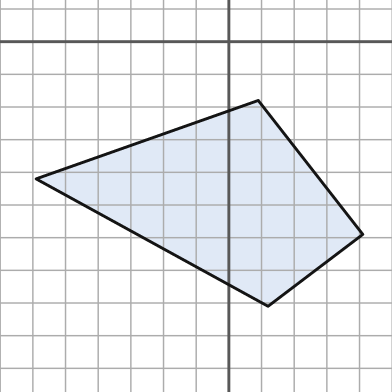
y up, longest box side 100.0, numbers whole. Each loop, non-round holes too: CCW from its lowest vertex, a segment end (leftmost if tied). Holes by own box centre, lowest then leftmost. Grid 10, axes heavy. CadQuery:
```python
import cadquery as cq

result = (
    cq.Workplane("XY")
    .moveTo(12.0, -81.0)
    .lineTo(41.0, -59.0)
    .lineTo(9.0, -18.0)
    .lineTo(-59.0, -42.0)
    .close()
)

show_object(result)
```